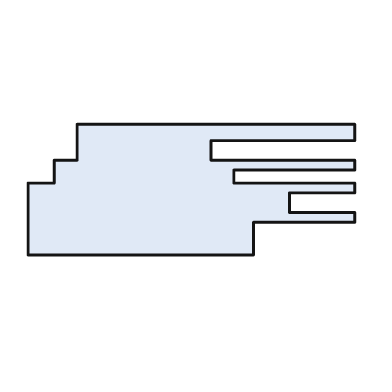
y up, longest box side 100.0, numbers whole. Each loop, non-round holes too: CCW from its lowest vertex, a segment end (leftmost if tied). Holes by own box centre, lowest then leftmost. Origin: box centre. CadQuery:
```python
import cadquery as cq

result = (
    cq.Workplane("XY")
    .moveTo(-50.0, -20.0)
    .lineTo(19.0, -20.0)
    .lineTo(19.0, -10.0)
    .lineTo(50.0, -10.0)
    .lineTo(50.0, -7.0)
    .lineTo(30.0, -7.0)
    .lineTo(30.0, -1.0)
    .lineTo(50.0, -1.0)
    .lineTo(50.0, 2.0)
    .lineTo(13.0, 2.0)
    .lineTo(13.0, 6.0)
    .lineTo(50.0, 6.0)
    .lineTo(50.0, 9.0)
    .lineTo(6.0, 9.0)
    .lineTo(6.0, 15.0)
    .lineTo(50.0, 15.0)
    .lineTo(50.0, 20.0)
    .lineTo(-35.0, 20.0)
    .lineTo(-35.0, 9.0)
    .lineTo(-42.0, 9.0)
    .lineTo(-42.0, 2.0)
    .lineTo(-50.0, 2.0)
    .close()
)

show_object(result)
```